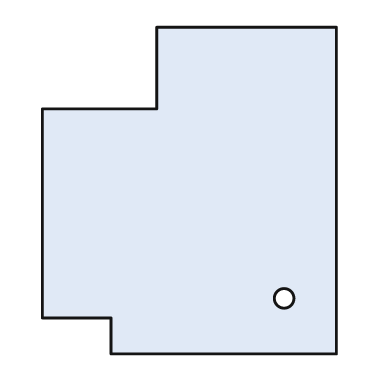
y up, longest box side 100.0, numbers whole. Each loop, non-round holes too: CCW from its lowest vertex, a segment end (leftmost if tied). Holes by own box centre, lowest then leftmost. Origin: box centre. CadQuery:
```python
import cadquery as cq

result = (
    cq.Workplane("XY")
    .moveTo(-24.0, -50.0)
    .lineTo(45.0, -50.0)
    .lineTo(45.0, 50.0)
    .lineTo(-10.0, 50.0)
    .lineTo(-10.0, 25.0)
    .lineTo(-45.0, 25.0)
    .lineTo(-45.0, -39.0)
    .lineTo(-24.0, -39.0)
    .close()
    .moveTo(29.0, -33.0)
    .circle(3.0)
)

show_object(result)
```